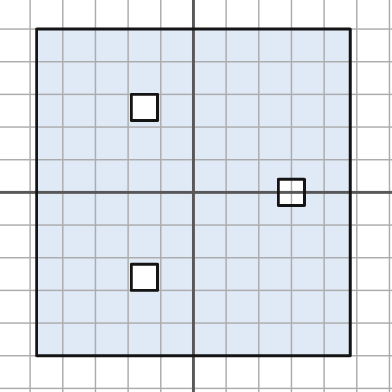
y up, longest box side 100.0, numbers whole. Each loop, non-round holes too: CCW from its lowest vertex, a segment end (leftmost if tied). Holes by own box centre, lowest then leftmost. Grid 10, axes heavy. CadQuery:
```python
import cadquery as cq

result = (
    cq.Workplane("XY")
    .moveTo(-48.0, -50.0)
    .lineTo(48.0, -50.0)
    .lineTo(48.0, 50.0)
    .lineTo(-48.0, 50.0)
    .close()
    .moveTo(-19.0, -30.0)
    .lineTo(-11.0, -30.0)
    .lineTo(-11.0, -22.0)
    .lineTo(-19.0, -22.0)
    .close()
    .moveTo(26.0, -4.0)
    .lineTo(34.0, -4.0)
    .lineTo(34.0, 4.0)
    .lineTo(26.0, 4.0)
    .close()
    .moveTo(-19.0, 22.0)
    .lineTo(-11.0, 22.0)
    .lineTo(-11.0, 30.0)
    .lineTo(-19.0, 30.0)
    .close()
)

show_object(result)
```